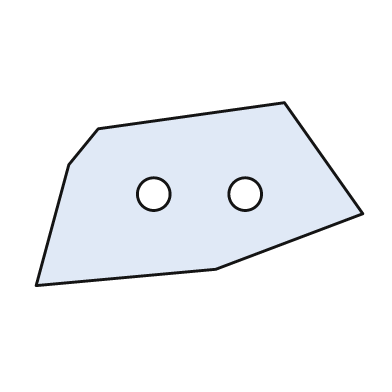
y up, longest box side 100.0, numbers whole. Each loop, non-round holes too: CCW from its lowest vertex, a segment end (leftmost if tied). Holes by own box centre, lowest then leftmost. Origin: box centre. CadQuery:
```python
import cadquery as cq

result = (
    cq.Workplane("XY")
    .moveTo(-50.0, -28.0)
    .lineTo(5.0, -23.0)
    .lineTo(50.0, -6.0)
    .lineTo(26.0, 28.0)
    .lineTo(-31.0, 20.0)
    .lineTo(-40.0, 9.0)
    .close()
    .moveTo(-14.0, 0.0)
    .circle(5.0)
    .moveTo(14.0, 0.0)
    .circle(5.0)
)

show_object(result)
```